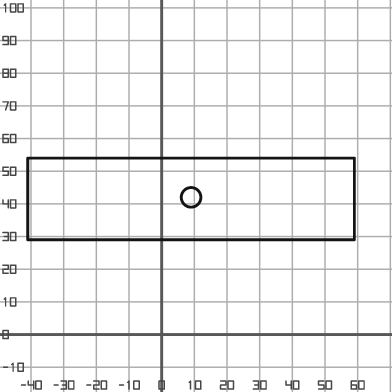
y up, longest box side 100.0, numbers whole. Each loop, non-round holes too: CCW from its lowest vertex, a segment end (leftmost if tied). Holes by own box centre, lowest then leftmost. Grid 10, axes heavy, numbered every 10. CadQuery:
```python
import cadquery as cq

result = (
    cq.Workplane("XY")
    .moveTo(-41.0, 29.0)
    .lineTo(59.0, 29.0)
    .lineTo(59.0, 54.0)
    .lineTo(-41.0, 54.0)
    .close()
    .moveTo(9.0, 42.0)
    .circle(3.0)
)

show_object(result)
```